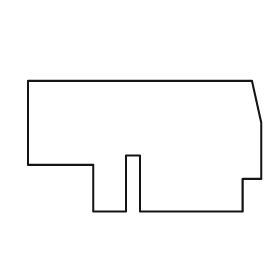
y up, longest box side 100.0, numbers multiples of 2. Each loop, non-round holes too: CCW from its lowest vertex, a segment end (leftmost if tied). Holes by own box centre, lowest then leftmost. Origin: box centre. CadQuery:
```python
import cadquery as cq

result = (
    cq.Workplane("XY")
    .moveTo(-22.0, -28.0)
    .lineTo(-8.0, -28.0)
    .lineTo(-8.0, -4.0)
    .lineTo(-2.0, -4.0)
    .lineTo(-2.0, -28.0)
    .lineTo(42.0, -28.0)
    .lineTo(42.0, -14.0)
    .lineTo(50.0, -14.0)
    .lineTo(50.0, 10.0)
    .lineTo(46.0, 28.0)
    .lineTo(-50.0, 28.0)
    .lineTo(-50.0, -8.0)
    .lineTo(-22.0, -8.0)
    .close()
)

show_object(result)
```